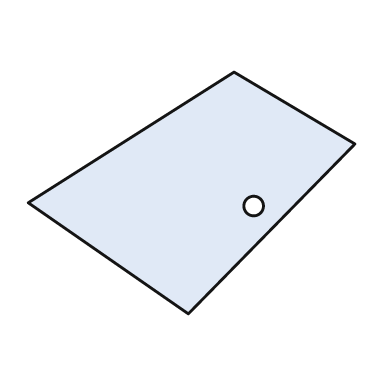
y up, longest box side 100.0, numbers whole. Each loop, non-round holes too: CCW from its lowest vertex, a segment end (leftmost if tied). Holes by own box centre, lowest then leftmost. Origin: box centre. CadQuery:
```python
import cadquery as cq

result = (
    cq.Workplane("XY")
    .moveTo(-1.0, -37.0)
    .lineTo(50.0, 15.0)
    .lineTo(13.0, 37.0)
    .lineTo(-50.0, -3.0)
    .close()
    .moveTo(19.0, -4.0)
    .circle(3.0)
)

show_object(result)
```